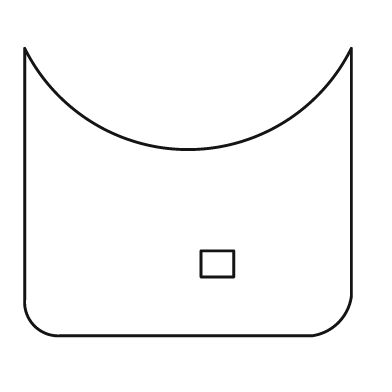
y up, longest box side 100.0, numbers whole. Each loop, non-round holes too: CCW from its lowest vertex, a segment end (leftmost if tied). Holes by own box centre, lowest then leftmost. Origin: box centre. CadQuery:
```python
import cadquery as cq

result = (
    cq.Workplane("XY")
    .moveTo(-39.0, -44.0)
    .lineTo(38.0, -44.0)
    .threePointArc((46.0, -40.0), (50.0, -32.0))
    .lineTo(50.0, 44.0)
    .threePointArc((0.0, 13.0), (-50.0, 44.0))
    .lineTo(-50.0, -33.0)
    .threePointArc((-47.0, -41.0), (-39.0, -44.0))
    .close()
    .moveTo(4.0, -26.0)
    .lineTo(14.0, -26.0)
    .lineTo(14.0, -18.0)
    .lineTo(4.0, -18.0)
    .close()
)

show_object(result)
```